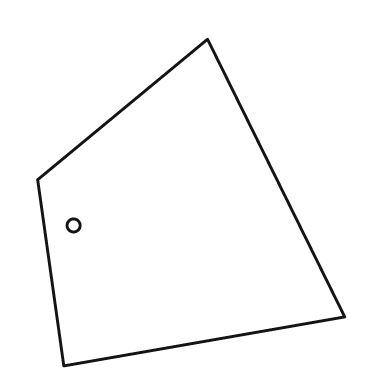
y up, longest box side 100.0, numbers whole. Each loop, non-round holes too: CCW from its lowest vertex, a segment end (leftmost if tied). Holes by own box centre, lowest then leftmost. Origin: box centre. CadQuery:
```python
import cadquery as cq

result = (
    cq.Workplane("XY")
    .moveTo(-39.0, -50.0)
    .lineTo(47.0, -35.0)
    .lineTo(5.0, 50.0)
    .lineTo(-47.0, 7.0)
    .close()
    .moveTo(-36.0, -7.0)
    .circle(2.0)
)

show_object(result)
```